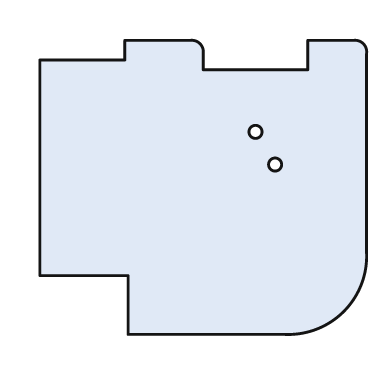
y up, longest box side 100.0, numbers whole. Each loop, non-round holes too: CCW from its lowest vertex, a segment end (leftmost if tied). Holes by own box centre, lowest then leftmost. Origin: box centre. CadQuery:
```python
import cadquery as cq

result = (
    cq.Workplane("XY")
    .moveTo(-23.0, -45.0)
    .lineTo(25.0, -45.0)
    .threePointArc((43.0, -38.0), (50.0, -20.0))
    .lineTo(50.0, 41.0)
    .threePointArc((49.0, 44.0), (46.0, 45.0))
    .lineTo(32.0, 45.0)
    .lineTo(32.0, 36.0)
    .lineTo(0.0, 36.0)
    .lineTo(0.0, 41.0)
    .threePointArc((-1.0, 44.0), (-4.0, 45.0))
    .lineTo(-24.0, 45.0)
    .lineTo(-24.0, 39.0)
    .lineTo(-50.0, 39.0)
    .lineTo(-50.0, -27.0)
    .lineTo(-23.0, -27.0)
    .close()
    .moveTo(22.0, 7.0)
    .circle(2.0)
    .moveTo(16.0, 17.0)
    .circle(2.0)
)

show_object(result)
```